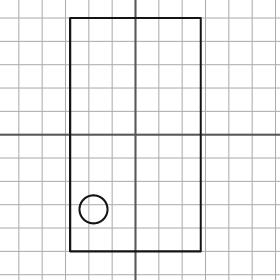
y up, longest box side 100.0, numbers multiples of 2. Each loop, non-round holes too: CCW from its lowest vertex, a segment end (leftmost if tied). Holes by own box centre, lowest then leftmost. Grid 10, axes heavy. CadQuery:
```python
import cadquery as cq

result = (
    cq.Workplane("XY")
    .moveTo(-28.0, -50.0)
    .lineTo(28.0, -50.0)
    .lineTo(28.0, 50.0)
    .lineTo(-28.0, 50.0)
    .close()
    .moveTo(-18.0, -32.0)
    .circle(6.0)
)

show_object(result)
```